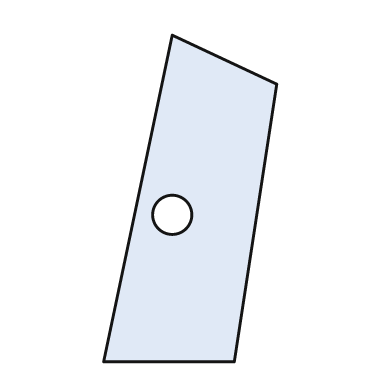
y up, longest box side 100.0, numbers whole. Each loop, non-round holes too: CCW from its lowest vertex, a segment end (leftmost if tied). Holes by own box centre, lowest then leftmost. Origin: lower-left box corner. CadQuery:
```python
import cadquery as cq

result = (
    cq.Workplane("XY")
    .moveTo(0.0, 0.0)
    .lineTo(40.0, 0.0)
    .lineTo(53.0, 85.0)
    .lineTo(21.0, 100.0)
    .close()
    .moveTo(21.0, 45.0)
    .circle(6.0)
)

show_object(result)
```